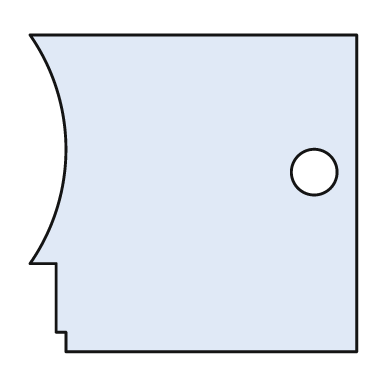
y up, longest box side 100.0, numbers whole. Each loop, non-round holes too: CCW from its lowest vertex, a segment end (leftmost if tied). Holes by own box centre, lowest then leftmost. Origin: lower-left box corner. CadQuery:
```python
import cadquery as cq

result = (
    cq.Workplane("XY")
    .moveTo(11.0, 0.0)
    .lineTo(100.0, 0.0)
    .lineTo(100.0, 97.0)
    .lineTo(0.0, 97.0)
    .threePointArc((11.0, 62.0), (0.0, 27.0))
    .lineTo(8.0, 27.0)
    .lineTo(8.0, 6.0)
    .lineTo(11.0, 6.0)
    .close()
    .moveTo(87.0, 55.0)
    .circle(7.0)
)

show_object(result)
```